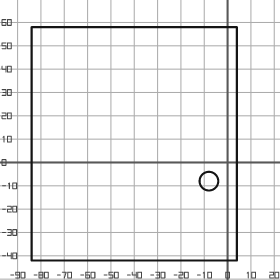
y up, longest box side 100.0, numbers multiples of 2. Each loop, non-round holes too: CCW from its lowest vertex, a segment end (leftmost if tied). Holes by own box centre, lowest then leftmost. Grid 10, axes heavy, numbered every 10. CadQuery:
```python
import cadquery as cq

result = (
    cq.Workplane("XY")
    .moveTo(-84.0, -42.0)
    .lineTo(4.0, -42.0)
    .lineTo(4.0, 58.0)
    .lineTo(-84.0, 58.0)
    .close()
    .moveTo(-8.0, -8.0)
    .circle(4.0)
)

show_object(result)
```